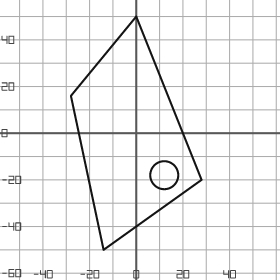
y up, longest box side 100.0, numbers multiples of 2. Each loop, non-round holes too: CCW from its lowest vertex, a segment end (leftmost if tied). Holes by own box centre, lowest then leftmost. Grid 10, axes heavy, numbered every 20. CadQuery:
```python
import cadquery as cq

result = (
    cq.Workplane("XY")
    .moveTo(-14.0, -50.0)
    .lineTo(28.0, -20.0)
    .lineTo(0.0, 50.0)
    .lineTo(-28.0, 16.0)
    .close()
    .moveTo(12.0, -18.0)
    .circle(6.0)
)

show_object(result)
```